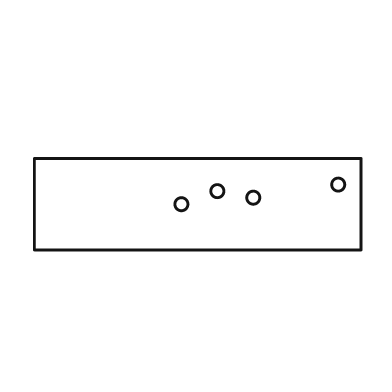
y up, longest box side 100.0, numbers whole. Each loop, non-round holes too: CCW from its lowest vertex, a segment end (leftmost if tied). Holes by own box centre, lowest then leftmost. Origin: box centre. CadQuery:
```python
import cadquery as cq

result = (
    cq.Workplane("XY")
    .moveTo(-50.0, -14.0)
    .lineTo(50.0, -14.0)
    .lineTo(50.0, 14.0)
    .lineTo(-50.0, 14.0)
    .close()
    .moveTo(-5.0, 0.0)
    .circle(2.0)
    .moveTo(17.0, 2.0)
    .circle(2.0)
    .moveTo(6.0, 4.0)
    .circle(2.0)
    .moveTo(43.0, 6.0)
    .circle(2.0)
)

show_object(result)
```